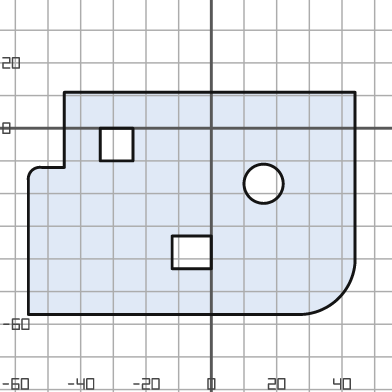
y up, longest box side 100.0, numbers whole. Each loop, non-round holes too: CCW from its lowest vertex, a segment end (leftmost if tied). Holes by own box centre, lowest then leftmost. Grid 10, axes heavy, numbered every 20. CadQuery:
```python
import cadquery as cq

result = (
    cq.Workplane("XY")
    .moveTo(-56.0, -57.0)
    .lineTo(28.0, -57.0)
    .threePointArc((39.0, -52.0), (44.0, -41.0))
    .lineTo(44.0, 11.0)
    .lineTo(-45.0, 11.0)
    .lineTo(-45.0, -12.0)
    .lineTo(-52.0, -12.0)
    .threePointArc((-55.0, -13.0), (-56.0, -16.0))
    .close()
    .moveTo(-12.0, -43.0)
    .lineTo(0.0, -43.0)
    .lineTo(0.0, -33.0)
    .lineTo(-12.0, -33.0)
    .close()
    .moveTo(16.0, -17.0)
    .circle(6.0)
    .moveTo(-34.0, -10.0)
    .lineTo(-24.0, -10.0)
    .lineTo(-24.0, 0.0)
    .lineTo(-34.0, 0.0)
    .close()
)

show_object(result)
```